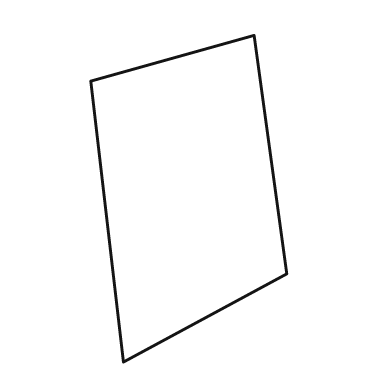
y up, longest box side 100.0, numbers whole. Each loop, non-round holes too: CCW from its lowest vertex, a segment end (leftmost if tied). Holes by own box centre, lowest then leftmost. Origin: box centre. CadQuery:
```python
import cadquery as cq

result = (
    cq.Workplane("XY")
    .moveTo(-20.0, -50.0)
    .lineTo(30.0, -23.0)
    .lineTo(20.0, 50.0)
    .lineTo(-30.0, 36.0)
    .close()
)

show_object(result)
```